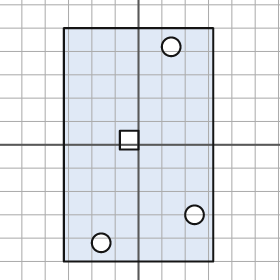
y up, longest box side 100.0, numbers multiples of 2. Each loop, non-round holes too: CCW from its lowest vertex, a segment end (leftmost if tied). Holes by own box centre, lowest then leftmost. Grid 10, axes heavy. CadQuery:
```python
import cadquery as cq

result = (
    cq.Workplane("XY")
    .moveTo(-32.0, -50.0)
    .lineTo(32.0, -50.0)
    .lineTo(32.0, 50.0)
    .lineTo(-32.0, 50.0)
    .close()
    .moveTo(-16.0, -42.0)
    .circle(4.0)
    .moveTo(24.0, -30.0)
    .circle(4.0)
    .moveTo(-8.0, -2.0)
    .lineTo(0.0, -2.0)
    .lineTo(0.0, 6.0)
    .lineTo(-8.0, 6.0)
    .close()
    .moveTo(14.0, 42.0)
    .circle(4.0)
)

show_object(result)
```